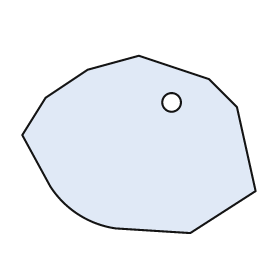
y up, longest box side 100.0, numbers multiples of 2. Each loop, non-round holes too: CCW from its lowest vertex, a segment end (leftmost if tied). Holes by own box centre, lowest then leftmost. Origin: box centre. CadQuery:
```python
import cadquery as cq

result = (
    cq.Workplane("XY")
    .moveTo(22.0, -38.0)
    .lineTo(50.0, -20.0)
    .lineTo(42.0, 16.0)
    .lineTo(30.0, 28.0)
    .lineTo(0.0, 38.0)
    .lineTo(-22.0, 32.0)
    .lineTo(-40.0, 20.0)
    .lineTo(-50.0, 4.0)
    .lineTo(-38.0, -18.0)
    .threePointArc((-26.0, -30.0), (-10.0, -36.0))
    .close()
    .moveTo(14.0, 18.0)
    .circle(4.0)
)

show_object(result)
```